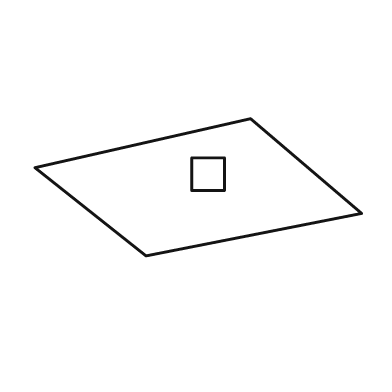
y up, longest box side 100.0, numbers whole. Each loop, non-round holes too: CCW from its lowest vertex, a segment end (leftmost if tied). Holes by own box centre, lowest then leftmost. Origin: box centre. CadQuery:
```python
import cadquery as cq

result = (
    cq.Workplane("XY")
    .moveTo(-16.0, -21.0)
    .lineTo(50.0, -8.0)
    .lineTo(16.0, 21.0)
    .lineTo(-50.0, 6.0)
    .close()
    .moveTo(-2.0, -1.0)
    .lineTo(8.0, -1.0)
    .lineTo(8.0, 9.0)
    .lineTo(-2.0, 9.0)
    .close()
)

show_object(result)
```